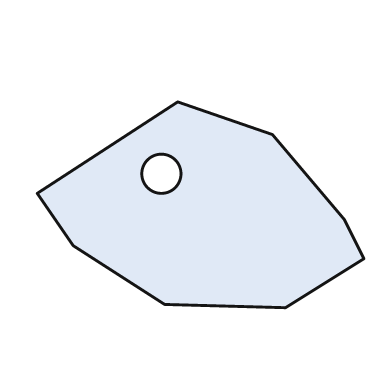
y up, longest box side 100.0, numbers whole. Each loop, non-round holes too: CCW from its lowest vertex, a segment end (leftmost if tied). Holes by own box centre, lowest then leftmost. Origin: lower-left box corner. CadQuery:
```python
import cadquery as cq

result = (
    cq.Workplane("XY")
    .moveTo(76.0, 0.0)
    .lineTo(100.0, 15.0)
    .lineTo(94.0, 27.0)
    .lineTo(72.0, 53.0)
    .lineTo(43.0, 63.0)
    .lineTo(0.0, 35.0)
    .lineTo(11.0, 19.0)
    .lineTo(39.0, 1.0)
    .close()
    .moveTo(38.0, 41.0)
    .circle(6.0)
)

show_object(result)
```